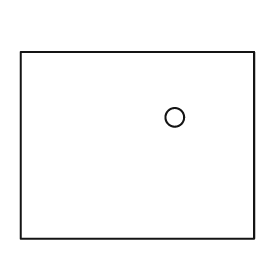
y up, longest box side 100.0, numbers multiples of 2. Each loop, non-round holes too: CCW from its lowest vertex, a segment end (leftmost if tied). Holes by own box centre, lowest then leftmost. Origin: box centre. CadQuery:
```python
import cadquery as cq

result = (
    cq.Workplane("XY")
    .moveTo(-50.0, -40.0)
    .lineTo(50.0, -40.0)
    .lineTo(50.0, 40.0)
    .lineTo(-50.0, 40.0)
    .close()
    .moveTo(16.0, 12.0)
    .circle(4.0)
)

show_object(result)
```